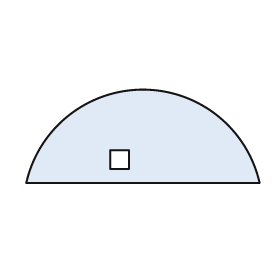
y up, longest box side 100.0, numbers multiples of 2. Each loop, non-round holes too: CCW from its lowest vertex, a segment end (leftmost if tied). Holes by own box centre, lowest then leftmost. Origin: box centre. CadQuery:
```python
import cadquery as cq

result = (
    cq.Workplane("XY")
    .moveTo(-50.0, -20.0)
    .lineTo(50.0, -20.0)
    .threePointArc((0.0, 20.0), (-50.0, -20.0))
    .close()
    .moveTo(-14.0, -14.0)
    .lineTo(-6.0, -14.0)
    .lineTo(-6.0, -6.0)
    .lineTo(-14.0, -6.0)
    .close()
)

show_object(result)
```